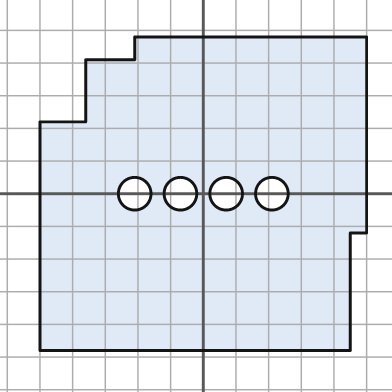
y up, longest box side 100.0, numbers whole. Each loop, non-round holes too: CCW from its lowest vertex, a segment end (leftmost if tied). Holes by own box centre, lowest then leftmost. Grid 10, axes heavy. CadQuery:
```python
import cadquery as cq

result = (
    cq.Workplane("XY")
    .moveTo(-50.0, -48.0)
    .lineTo(45.0, -48.0)
    .lineTo(45.0, -12.0)
    .lineTo(50.0, -12.0)
    .lineTo(50.0, 48.0)
    .lineTo(-21.0, 48.0)
    .lineTo(-21.0, 41.0)
    .lineTo(-36.0, 41.0)
    .lineTo(-36.0, 22.0)
    .lineTo(-50.0, 22.0)
    .close()
    .moveTo(-21.0, 0.0)
    .circle(5.0)
    .moveTo(-7.0, 0.0)
    .circle(5.0)
    .moveTo(7.0, 0.0)
    .circle(5.0)
    .moveTo(21.0, 0.0)
    .circle(5.0)
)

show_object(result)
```